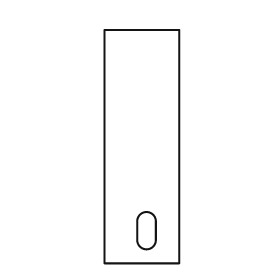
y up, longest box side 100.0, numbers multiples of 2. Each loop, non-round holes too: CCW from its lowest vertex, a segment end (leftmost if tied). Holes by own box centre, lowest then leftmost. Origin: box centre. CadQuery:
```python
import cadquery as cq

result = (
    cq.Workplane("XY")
    .moveTo(-16.0, -50.0)
    .lineTo(16.0, -50.0)
    .lineTo(16.0, 50.0)
    .lineTo(-16.0, 50.0)
    .close()
    .moveTo(-2.0, -40.0)
    .threePointArc((2.0, -44.0), (6.0, -40.0))
    .lineTo(6.0, -32.0)
    .threePointArc((2.0, -28.0), (-2.0, -32.0))
    .close()
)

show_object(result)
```